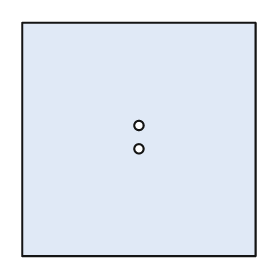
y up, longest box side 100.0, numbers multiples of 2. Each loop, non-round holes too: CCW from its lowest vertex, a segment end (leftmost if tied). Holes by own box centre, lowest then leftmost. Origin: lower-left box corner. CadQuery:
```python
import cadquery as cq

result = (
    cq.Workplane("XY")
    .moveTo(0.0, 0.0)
    .lineTo(100.0, 0.0)
    .lineTo(100.0, 100.0)
    .lineTo(0.0, 100.0)
    .close()
    .moveTo(50.0, 46.0)
    .circle(2.0)
    .moveTo(50.0, 56.0)
    .circle(2.0)
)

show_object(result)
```